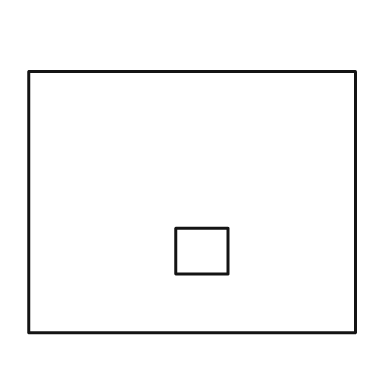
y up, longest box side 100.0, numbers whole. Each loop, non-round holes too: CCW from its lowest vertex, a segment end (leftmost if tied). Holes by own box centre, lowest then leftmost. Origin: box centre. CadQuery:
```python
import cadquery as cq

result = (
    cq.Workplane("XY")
    .moveTo(-50.0, -40.0)
    .lineTo(50.0, -40.0)
    .lineTo(50.0, 40.0)
    .lineTo(-50.0, 40.0)
    .close()
    .moveTo(-5.0, -22.0)
    .lineTo(11.0, -22.0)
    .lineTo(11.0, -8.0)
    .lineTo(-5.0, -8.0)
    .close()
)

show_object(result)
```